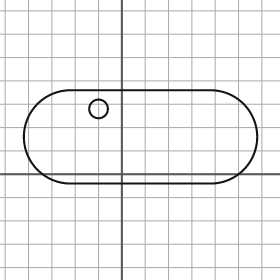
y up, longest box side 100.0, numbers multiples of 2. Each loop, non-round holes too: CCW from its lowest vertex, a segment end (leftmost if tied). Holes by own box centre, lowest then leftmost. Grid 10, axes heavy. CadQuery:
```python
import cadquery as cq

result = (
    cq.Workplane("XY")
    .moveTo(-22.0, -4.0)
    .lineTo(38.0, -4.0)
    .threePointArc((58.0, 16.0), (38.0, 36.0))
    .lineTo(-22.0, 36.0)
    .threePointArc((-42.0, 16.0), (-22.0, -4.0))
    .close()
    .moveTo(-10.0, 28.0)
    .circle(4.0)
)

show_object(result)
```